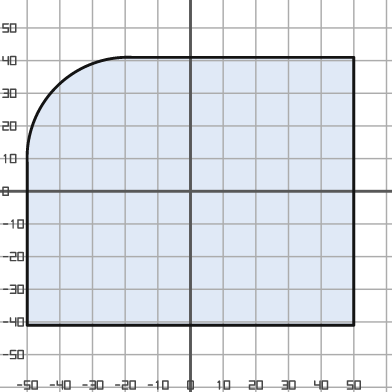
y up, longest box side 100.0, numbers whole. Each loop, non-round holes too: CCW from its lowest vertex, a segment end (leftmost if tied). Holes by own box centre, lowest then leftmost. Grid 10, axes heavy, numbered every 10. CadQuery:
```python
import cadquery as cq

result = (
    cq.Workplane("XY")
    .moveTo(-50.0, -41.0)
    .lineTo(50.0, -41.0)
    .lineTo(50.0, 41.0)
    .lineTo(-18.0, 41.0)
    .threePointArc((-41.0, 32.0), (-50.0, 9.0))
    .close()
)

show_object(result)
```